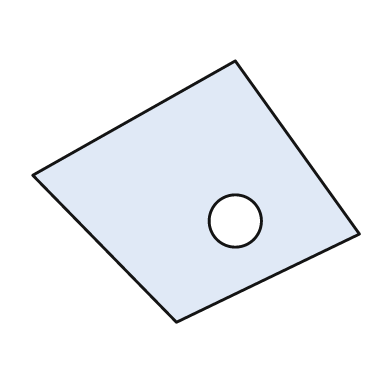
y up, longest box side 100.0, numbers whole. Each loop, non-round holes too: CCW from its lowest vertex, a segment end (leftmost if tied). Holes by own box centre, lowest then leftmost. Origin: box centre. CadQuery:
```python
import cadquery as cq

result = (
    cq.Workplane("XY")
    .moveTo(-6.0, -40.0)
    .lineTo(50.0, -13.0)
    .lineTo(12.0, 40.0)
    .lineTo(-50.0, 5.0)
    .close()
    .moveTo(12.0, -9.0)
    .circle(8.0)
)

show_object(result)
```